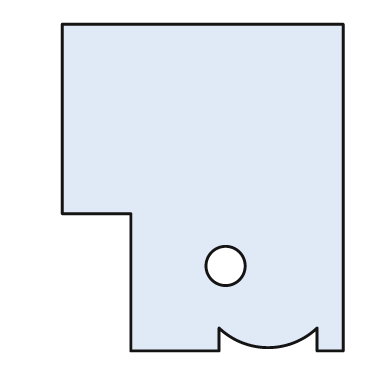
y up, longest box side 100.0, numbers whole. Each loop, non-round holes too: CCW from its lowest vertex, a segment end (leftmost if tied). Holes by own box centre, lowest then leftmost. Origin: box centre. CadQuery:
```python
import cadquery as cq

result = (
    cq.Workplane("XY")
    .moveTo(-22.0, -50.0)
    .lineTo(5.0, -50.0)
    .lineTo(5.0, -43.0)
    .threePointArc((20.0, -49.0), (35.0, -43.0))
    .lineTo(35.0, -50.0)
    .lineTo(43.0, -50.0)
    .lineTo(43.0, 50.0)
    .lineTo(-43.0, 50.0)
    .lineTo(-43.0, -8.0)
    .lineTo(-22.0, -8.0)
    .close()
    .moveTo(7.0, -24.0)
    .circle(6.0)
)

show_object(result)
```